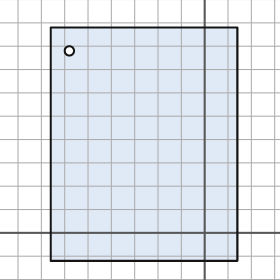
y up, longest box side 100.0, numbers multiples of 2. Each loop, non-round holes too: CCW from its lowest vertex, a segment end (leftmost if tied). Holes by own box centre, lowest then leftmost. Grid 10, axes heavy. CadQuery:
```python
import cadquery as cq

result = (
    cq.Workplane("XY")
    .moveTo(-66.0, -12.0)
    .lineTo(14.0, -12.0)
    .lineTo(14.0, 88.0)
    .lineTo(-66.0, 88.0)
    .close()
    .moveTo(-58.0, 78.0)
    .circle(2.0)
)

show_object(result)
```